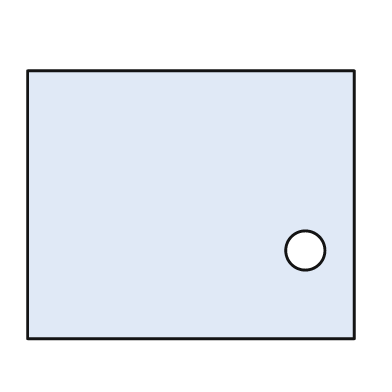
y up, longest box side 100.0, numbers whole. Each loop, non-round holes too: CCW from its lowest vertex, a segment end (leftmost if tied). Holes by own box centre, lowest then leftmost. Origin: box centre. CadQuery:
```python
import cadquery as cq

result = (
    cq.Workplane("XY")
    .moveTo(-50.0, -41.0)
    .lineTo(50.0, -41.0)
    .lineTo(50.0, 41.0)
    .lineTo(-50.0, 41.0)
    .close()
    .moveTo(35.0, -14.0)
    .circle(6.0)
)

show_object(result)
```